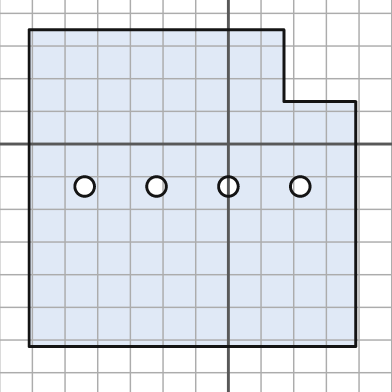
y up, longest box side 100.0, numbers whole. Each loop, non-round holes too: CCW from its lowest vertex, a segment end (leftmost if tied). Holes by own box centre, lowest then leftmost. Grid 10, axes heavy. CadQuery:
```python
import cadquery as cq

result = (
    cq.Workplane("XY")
    .moveTo(-61.0, -62.0)
    .lineTo(39.0, -62.0)
    .lineTo(39.0, 13.0)
    .lineTo(17.0, 13.0)
    .lineTo(17.0, 35.0)
    .lineTo(-61.0, 35.0)
    .close()
    .moveTo(-44.0, -13.0)
    .circle(3.0)
    .moveTo(-22.0, -13.0)
    .circle(3.0)
    .moveTo(0.0, -13.0)
    .circle(3.0)
    .moveTo(22.0, -13.0)
    .circle(3.0)
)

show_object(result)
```